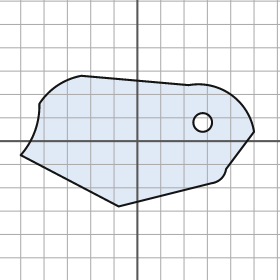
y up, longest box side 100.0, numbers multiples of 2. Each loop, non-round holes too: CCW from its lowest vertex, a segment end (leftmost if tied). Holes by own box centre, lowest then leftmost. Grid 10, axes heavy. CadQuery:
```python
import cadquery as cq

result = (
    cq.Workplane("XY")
    .moveTo(-8.0, -28.0)
    .lineTo(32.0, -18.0)
    .threePointArc((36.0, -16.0), (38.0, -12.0))
    .lineTo(50.0, 4.0)
    .threePointArc((40.0, 20.0), (22.0, 24.0))
    .lineTo(-24.0, 28.0)
    .threePointArc((-34.0, 24.0), (-42.0, 16.0))
    .threePointArc((-44.0, 4.0), (-50.0, -6.0))
    .close()
    .moveTo(28.0, 8.0)
    .circle(4.0)
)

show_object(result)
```